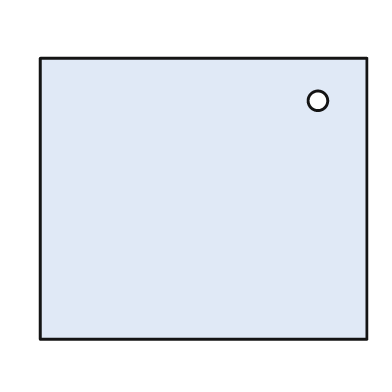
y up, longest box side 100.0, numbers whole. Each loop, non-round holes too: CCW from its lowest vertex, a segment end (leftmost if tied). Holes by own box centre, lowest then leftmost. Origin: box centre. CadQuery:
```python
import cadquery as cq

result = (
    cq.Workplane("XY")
    .moveTo(-50.0, -43.0)
    .lineTo(50.0, -43.0)
    .lineTo(50.0, 43.0)
    .lineTo(-50.0, 43.0)
    .close()
    .moveTo(35.0, 30.0)
    .circle(3.0)
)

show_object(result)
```